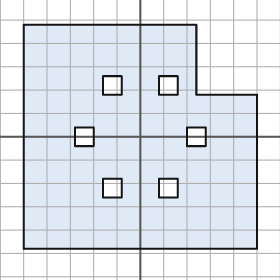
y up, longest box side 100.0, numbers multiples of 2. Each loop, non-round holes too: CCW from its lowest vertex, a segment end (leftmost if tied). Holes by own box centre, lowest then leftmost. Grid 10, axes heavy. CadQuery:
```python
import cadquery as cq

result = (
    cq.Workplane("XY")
    .moveTo(-50.0, -48.0)
    .lineTo(50.0, -48.0)
    .lineTo(50.0, 18.0)
    .lineTo(24.0, 18.0)
    .lineTo(24.0, 48.0)
    .lineTo(-50.0, 48.0)
    .close()
    .moveTo(-16.0, -26.0)
    .lineTo(-8.0, -26.0)
    .lineTo(-8.0, -18.0)
    .lineTo(-16.0, -18.0)
    .close()
    .moveTo(8.0, -26.0)
    .lineTo(16.0, -26.0)
    .lineTo(16.0, -18.0)
    .lineTo(8.0, -18.0)
    .close()
    .moveTo(-28.0, -4.0)
    .lineTo(-20.0, -4.0)
    .lineTo(-20.0, 4.0)
    .lineTo(-28.0, 4.0)
    .close()
    .moveTo(20.0, -4.0)
    .lineTo(28.0, -4.0)
    .lineTo(28.0, 4.0)
    .lineTo(20.0, 4.0)
    .close()
    .moveTo(-16.0, 18.0)
    .lineTo(-8.0, 18.0)
    .lineTo(-8.0, 26.0)
    .lineTo(-16.0, 26.0)
    .close()
    .moveTo(8.0, 18.0)
    .lineTo(16.0, 18.0)
    .lineTo(16.0, 26.0)
    .lineTo(8.0, 26.0)
    .close()
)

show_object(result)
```